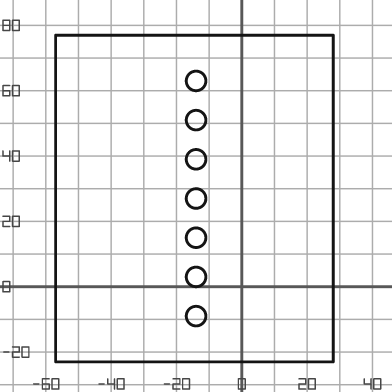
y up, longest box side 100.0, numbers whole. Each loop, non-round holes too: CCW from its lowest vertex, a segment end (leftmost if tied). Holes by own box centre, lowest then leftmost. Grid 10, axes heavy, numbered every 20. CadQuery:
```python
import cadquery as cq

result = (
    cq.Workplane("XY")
    .moveTo(-57.0, -23.0)
    .lineTo(28.0, -23.0)
    .lineTo(28.0, 77.0)
    .lineTo(-57.0, 77.0)
    .close()
    .moveTo(-14.0, -9.0)
    .circle(3.0)
    .moveTo(-14.0, 3.0)
    .circle(3.0)
    .moveTo(-14.0, 15.0)
    .circle(3.0)
    .moveTo(-14.0, 27.0)
    .circle(3.0)
    .moveTo(-14.0, 39.0)
    .circle(3.0)
    .moveTo(-14.0, 51.0)
    .circle(3.0)
    .moveTo(-14.0, 63.0)
    .circle(3.0)
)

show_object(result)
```